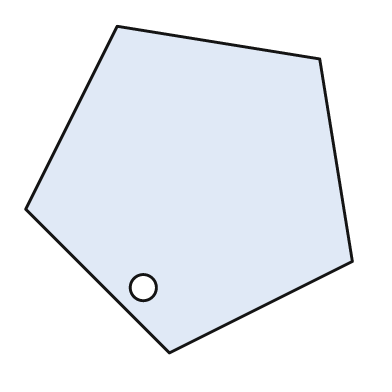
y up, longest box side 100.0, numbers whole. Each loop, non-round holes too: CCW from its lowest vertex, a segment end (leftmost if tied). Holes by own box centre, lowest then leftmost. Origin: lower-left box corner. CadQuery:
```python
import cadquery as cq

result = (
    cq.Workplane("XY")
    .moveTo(44.0, 0.0)
    .lineTo(100.0, 28.0)
    .lineTo(90.0, 90.0)
    .lineTo(28.0, 100.0)
    .lineTo(0.0, 44.0)
    .close()
    .moveTo(36.0, 20.0)
    .circle(4.0)
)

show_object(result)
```